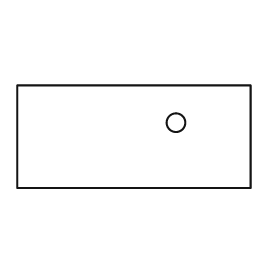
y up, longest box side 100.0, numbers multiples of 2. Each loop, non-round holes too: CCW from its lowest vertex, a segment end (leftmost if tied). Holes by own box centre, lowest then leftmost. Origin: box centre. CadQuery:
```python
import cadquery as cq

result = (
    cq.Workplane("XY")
    .moveTo(-50.0, -22.0)
    .lineTo(50.0, -22.0)
    .lineTo(50.0, 22.0)
    .lineTo(-50.0, 22.0)
    .close()
    .moveTo(18.0, 6.0)
    .circle(4.0)
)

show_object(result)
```